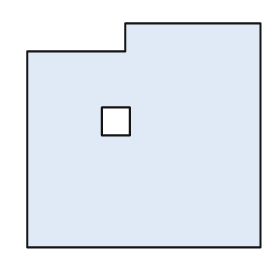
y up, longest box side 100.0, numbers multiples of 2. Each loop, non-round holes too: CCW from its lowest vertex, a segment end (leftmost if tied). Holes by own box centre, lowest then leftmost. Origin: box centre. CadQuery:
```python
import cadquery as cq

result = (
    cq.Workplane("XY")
    .moveTo(-50.0, -48.0)
    .lineTo(50.0, -48.0)
    .lineTo(50.0, 48.0)
    .lineTo(-8.0, 48.0)
    .lineTo(-8.0, 36.0)
    .lineTo(-50.0, 36.0)
    .close()
    .moveTo(-18.0, 0.0)
    .lineTo(-6.0, 0.0)
    .lineTo(-6.0, 12.0)
    .lineTo(-18.0, 12.0)
    .close()
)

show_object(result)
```